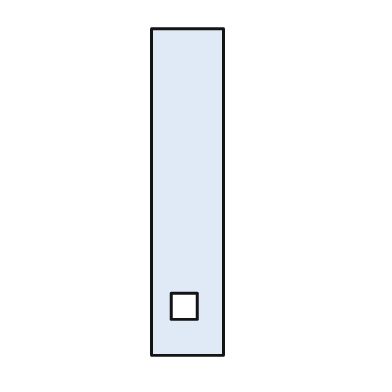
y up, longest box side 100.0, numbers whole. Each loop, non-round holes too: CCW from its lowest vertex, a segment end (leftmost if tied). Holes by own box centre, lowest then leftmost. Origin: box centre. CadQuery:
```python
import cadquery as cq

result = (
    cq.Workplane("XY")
    .moveTo(-11.0, -50.0)
    .lineTo(11.0, -50.0)
    .lineTo(11.0, 50.0)
    .lineTo(-11.0, 50.0)
    .close()
    .moveTo(-5.0, -39.0)
    .lineTo(3.0, -39.0)
    .lineTo(3.0, -31.0)
    .lineTo(-5.0, -31.0)
    .close()
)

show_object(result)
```